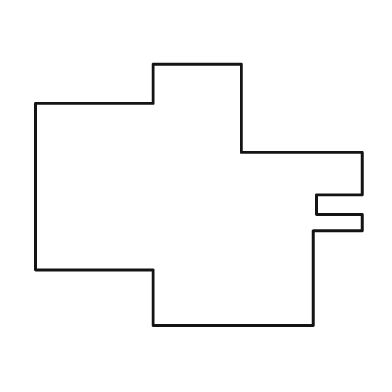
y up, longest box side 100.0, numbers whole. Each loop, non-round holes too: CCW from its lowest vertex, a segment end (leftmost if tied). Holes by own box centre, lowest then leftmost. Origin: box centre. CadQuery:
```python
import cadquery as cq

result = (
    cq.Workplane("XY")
    .moveTo(-14.0, -40.0)
    .lineTo(35.0, -40.0)
    .lineTo(35.0, -11.0)
    .lineTo(50.0, -11.0)
    .lineTo(50.0, -6.0)
    .lineTo(36.0, -6.0)
    .lineTo(36.0, 0.0)
    .lineTo(50.0, 0.0)
    .lineTo(50.0, 13.0)
    .lineTo(13.0, 13.0)
    .lineTo(13.0, 40.0)
    .lineTo(-14.0, 40.0)
    .lineTo(-14.0, 28.0)
    .lineTo(-50.0, 28.0)
    .lineTo(-50.0, -23.0)
    .lineTo(-14.0, -23.0)
    .close()
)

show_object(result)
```